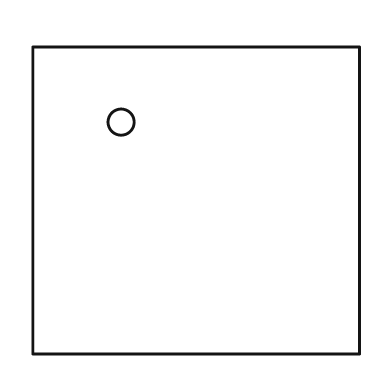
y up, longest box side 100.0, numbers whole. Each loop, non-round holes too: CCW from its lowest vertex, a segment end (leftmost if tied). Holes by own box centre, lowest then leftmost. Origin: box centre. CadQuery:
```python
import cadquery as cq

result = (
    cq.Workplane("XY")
    .moveTo(-50.0, -47.0)
    .lineTo(50.0, -47.0)
    .lineTo(50.0, 47.0)
    .lineTo(-50.0, 47.0)
    .close()
    .moveTo(-23.0, 24.0)
    .circle(4.0)
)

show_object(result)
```